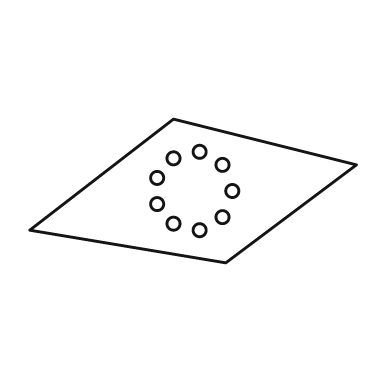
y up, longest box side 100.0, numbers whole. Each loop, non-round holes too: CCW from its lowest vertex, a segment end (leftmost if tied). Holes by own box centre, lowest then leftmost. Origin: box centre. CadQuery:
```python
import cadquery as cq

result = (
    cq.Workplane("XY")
    .moveTo(10.0, -22.0)
    .lineTo(50.0, 8.0)
    .lineTo(-6.0, 22.0)
    .lineTo(-50.0, -12.0)
    .close()
    .moveTo(2.0, -12.0)
    .circle(2.0)
    .moveTo(-6.0, -10.0)
    .circle(2.0)
    .moveTo(9.0, -8.0)
    .circle(2.0)
    .moveTo(-11.0, -4.0)
    .circle(2.0)
    .moveTo(12.0, 0.0)
    .circle(2.0)
    .moveTo(-11.0, 4.0)
    .circle(2.0)
    .moveTo(9.0, 8.0)
    .circle(2.0)
    .moveTo(-6.0, 10.0)
    .circle(2.0)
    .moveTo(2.0, 12.0)
    .circle(2.0)
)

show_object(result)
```